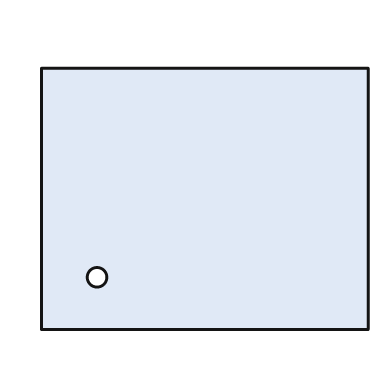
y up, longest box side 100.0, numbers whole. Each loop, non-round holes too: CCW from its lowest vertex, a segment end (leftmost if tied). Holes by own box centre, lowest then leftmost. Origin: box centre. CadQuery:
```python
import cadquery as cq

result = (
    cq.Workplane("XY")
    .moveTo(-50.0, -40.0)
    .lineTo(50.0, -40.0)
    .lineTo(50.0, 40.0)
    .lineTo(-50.0, 40.0)
    .close()
    .moveTo(-33.0, -24.0)
    .circle(3.0)
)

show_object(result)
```